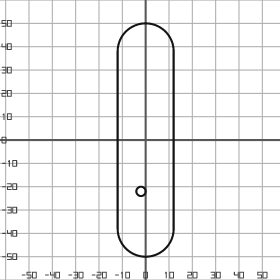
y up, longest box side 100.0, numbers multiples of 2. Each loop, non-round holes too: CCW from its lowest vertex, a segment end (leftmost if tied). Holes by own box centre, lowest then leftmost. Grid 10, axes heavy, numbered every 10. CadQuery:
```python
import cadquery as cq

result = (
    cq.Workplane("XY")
    .moveTo(-12.0, -38.0)
    .threePointArc((0.0, -50.0), (12.0, -38.0))
    .lineTo(12.0, 38.0)
    .threePointArc((0.0, 50.0), (-12.0, 38.0))
    .close()
    .moveTo(-2.0, -22.0)
    .circle(2.0)
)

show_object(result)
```